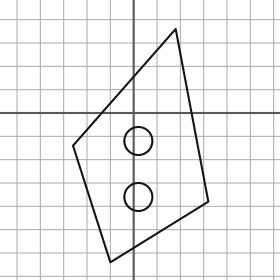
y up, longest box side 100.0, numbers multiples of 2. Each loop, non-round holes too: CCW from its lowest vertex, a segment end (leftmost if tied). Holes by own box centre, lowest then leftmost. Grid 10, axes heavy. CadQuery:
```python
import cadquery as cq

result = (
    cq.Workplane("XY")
    .moveTo(-10.0, -64.0)
    .lineTo(32.0, -38.0)
    .lineTo(18.0, 36.0)
    .lineTo(-26.0, -14.0)
    .close()
    .moveTo(2.0, -36.0)
    .circle(6.0)
    .moveTo(2.0, -12.0)
    .circle(6.0)
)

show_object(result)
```